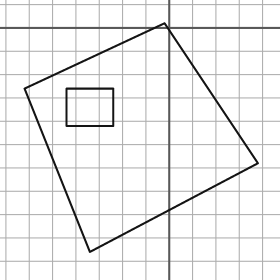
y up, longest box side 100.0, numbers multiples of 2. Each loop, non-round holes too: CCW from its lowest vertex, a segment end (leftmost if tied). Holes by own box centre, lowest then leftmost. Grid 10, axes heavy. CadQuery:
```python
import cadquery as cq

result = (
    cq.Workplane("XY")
    .moveTo(-34.0, -96.0)
    .lineTo(38.0, -58.0)
    .lineTo(-2.0, 2.0)
    .lineTo(-62.0, -26.0)
    .close()
    .moveTo(-44.0, -42.0)
    .lineTo(-24.0, -42.0)
    .lineTo(-24.0, -26.0)
    .lineTo(-44.0, -26.0)
    .close()
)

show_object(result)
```